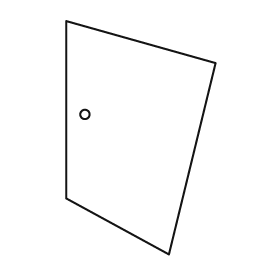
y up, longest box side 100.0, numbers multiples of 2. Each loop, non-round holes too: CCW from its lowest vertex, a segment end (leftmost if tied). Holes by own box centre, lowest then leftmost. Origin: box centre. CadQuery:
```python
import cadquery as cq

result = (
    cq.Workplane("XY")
    .moveTo(12.0, -50.0)
    .lineTo(32.0, 32.0)
    .lineTo(-32.0, 50.0)
    .lineTo(-32.0, -26.0)
    .close()
    .moveTo(-24.0, 10.0)
    .circle(2.0)
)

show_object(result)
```